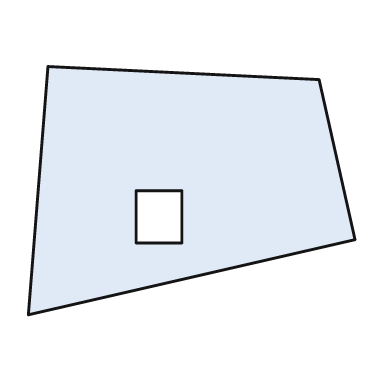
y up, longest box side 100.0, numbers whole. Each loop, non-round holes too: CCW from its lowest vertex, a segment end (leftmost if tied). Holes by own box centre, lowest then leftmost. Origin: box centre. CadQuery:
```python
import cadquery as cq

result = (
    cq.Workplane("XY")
    .moveTo(-50.0, -38.0)
    .lineTo(50.0, -15.0)
    .lineTo(39.0, 34.0)
    .lineTo(-44.0, 38.0)
    .close()
    .moveTo(-17.0, -16.0)
    .lineTo(-3.0, -16.0)
    .lineTo(-3.0, 0.0)
    .lineTo(-17.0, 0.0)
    .close()
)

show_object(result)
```